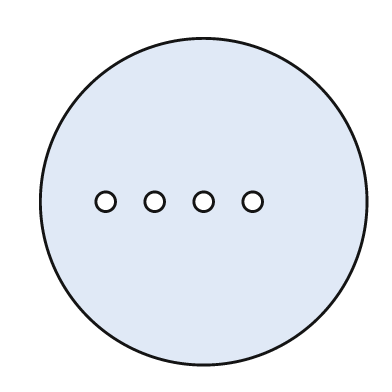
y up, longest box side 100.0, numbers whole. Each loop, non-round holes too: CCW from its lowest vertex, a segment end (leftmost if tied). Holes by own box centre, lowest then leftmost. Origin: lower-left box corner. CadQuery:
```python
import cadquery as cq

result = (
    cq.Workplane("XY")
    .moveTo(50.0, 50.0)
    .circle(50.0)
    .moveTo(20.0, 50.0)
    .circle(3.0)
    .moveTo(35.0, 50.0)
    .circle(3.0)
    .moveTo(50.0, 50.0)
    .circle(3.0)
    .moveTo(65.0, 50.0)
    .circle(3.0)
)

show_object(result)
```